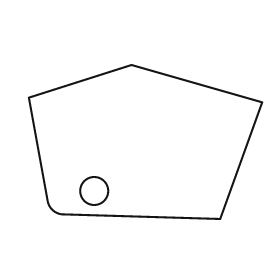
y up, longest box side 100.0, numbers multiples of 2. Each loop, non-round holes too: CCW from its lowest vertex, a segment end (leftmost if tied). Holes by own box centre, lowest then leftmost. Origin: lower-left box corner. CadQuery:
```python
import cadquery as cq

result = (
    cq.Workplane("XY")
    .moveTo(82.0, 0.0)
    .lineTo(100.0, 50.0)
    .lineTo(44.0, 66.0)
    .lineTo(0.0, 52.0)
    .lineTo(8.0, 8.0)
    .threePointArc((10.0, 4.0), (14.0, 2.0))
    .close()
    .moveTo(28.0, 12.0)
    .circle(6.0)
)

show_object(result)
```